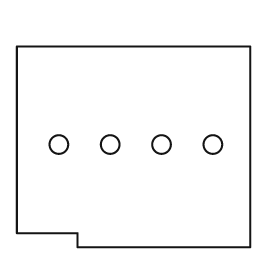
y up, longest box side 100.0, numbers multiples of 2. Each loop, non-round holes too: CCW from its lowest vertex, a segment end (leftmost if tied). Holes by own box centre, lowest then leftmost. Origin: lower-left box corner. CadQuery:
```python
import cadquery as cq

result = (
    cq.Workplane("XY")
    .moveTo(26.0, 0.0)
    .lineTo(100.0, 0.0)
    .lineTo(100.0, 86.0)
    .lineTo(0.0, 86.0)
    .lineTo(0.0, 6.0)
    .lineTo(26.0, 6.0)
    .close()
    .moveTo(18.0, 44.0)
    .circle(4.0)
    .moveTo(40.0, 44.0)
    .circle(4.0)
    .moveTo(62.0, 44.0)
    .circle(4.0)
    .moveTo(84.0, 44.0)
    .circle(4.0)
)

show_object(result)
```